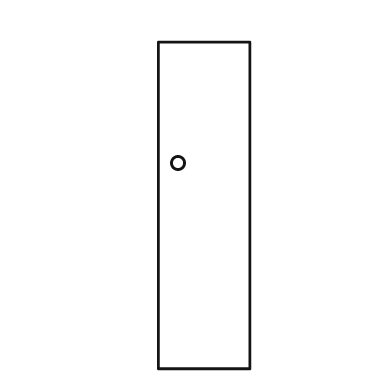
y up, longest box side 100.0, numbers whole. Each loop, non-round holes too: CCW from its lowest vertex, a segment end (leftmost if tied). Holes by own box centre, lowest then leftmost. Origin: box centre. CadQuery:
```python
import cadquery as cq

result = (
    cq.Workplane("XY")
    .moveTo(-14.0, -50.0)
    .lineTo(14.0, -50.0)
    .lineTo(14.0, 50.0)
    .lineTo(-14.0, 50.0)
    .close()
    .moveTo(-8.0, 13.0)
    .circle(2.0)
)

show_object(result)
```